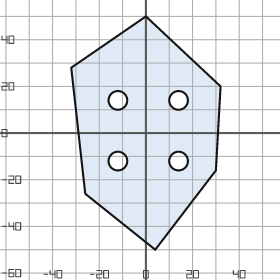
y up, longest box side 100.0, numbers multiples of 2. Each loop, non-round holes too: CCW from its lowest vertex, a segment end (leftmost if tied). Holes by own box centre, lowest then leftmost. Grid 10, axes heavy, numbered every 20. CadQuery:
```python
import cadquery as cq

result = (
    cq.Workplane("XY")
    .moveTo(4.0, -50.0)
    .lineTo(30.0, -16.0)
    .lineTo(32.0, 20.0)
    .lineTo(0.0, 50.0)
    .lineTo(-32.0, 28.0)
    .lineTo(-26.0, -26.0)
    .close()
    .moveTo(-12.0, -12.0)
    .circle(4.0)
    .moveTo(14.0, -12.0)
    .circle(4.0)
    .moveTo(-12.0, 14.0)
    .circle(4.0)
    .moveTo(14.0, 14.0)
    .circle(4.0)
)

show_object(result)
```